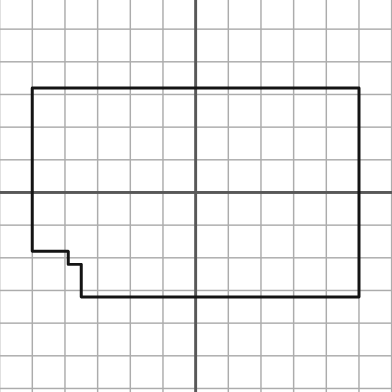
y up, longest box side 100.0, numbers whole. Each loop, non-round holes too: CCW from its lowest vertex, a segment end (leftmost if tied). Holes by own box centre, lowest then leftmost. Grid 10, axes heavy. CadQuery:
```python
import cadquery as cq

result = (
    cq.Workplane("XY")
    .moveTo(-35.0, -32.0)
    .lineTo(50.0, -32.0)
    .lineTo(50.0, 32.0)
    .lineTo(-50.0, 32.0)
    .lineTo(-50.0, -18.0)
    .lineTo(-39.0, -18.0)
    .lineTo(-39.0, -22.0)
    .lineTo(-35.0, -22.0)
    .close()
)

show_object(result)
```